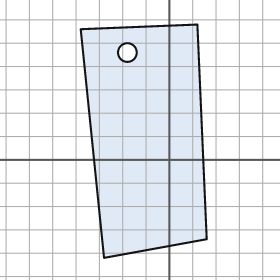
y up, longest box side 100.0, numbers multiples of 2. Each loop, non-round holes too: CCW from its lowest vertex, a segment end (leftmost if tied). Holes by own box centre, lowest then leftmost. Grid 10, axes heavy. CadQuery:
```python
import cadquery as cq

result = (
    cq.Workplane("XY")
    .moveTo(-28.0, -42.0)
    .lineTo(16.0, -34.0)
    .lineTo(12.0, 58.0)
    .lineTo(-38.0, 56.0)
    .close()
    .moveTo(-18.0, 46.0)
    .circle(4.0)
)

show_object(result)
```